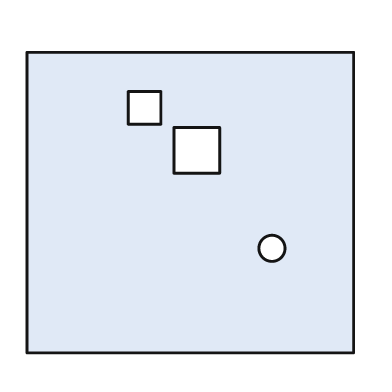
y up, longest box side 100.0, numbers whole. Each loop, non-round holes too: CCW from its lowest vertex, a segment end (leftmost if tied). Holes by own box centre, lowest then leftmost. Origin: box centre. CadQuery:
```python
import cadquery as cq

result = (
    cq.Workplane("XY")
    .moveTo(-50.0, -46.0)
    .lineTo(50.0, -46.0)
    .lineTo(50.0, 46.0)
    .lineTo(-50.0, 46.0)
    .close()
    .moveTo(25.0, -14.0)
    .circle(4.0)
    .moveTo(-5.0, 9.0)
    .lineTo(9.0, 9.0)
    .lineTo(9.0, 23.0)
    .lineTo(-5.0, 23.0)
    .close()
    .moveTo(-19.0, 24.0)
    .lineTo(-9.0, 24.0)
    .lineTo(-9.0, 34.0)
    .lineTo(-19.0, 34.0)
    .close()
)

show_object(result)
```